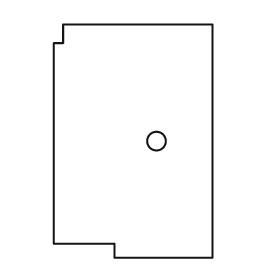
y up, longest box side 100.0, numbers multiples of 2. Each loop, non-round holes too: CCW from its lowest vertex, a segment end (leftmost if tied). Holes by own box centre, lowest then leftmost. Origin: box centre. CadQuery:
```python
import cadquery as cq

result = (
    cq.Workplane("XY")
    .moveTo(-8.0, -50.0)
    .lineTo(34.0, -50.0)
    .lineTo(34.0, 50.0)
    .lineTo(-30.0, 50.0)
    .lineTo(-30.0, 42.0)
    .lineTo(-34.0, 42.0)
    .lineTo(-34.0, -44.0)
    .lineTo(-8.0, -44.0)
    .close()
    .moveTo(10.0, 0.0)
    .circle(4.0)
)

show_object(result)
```